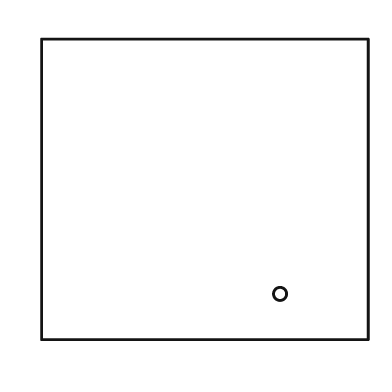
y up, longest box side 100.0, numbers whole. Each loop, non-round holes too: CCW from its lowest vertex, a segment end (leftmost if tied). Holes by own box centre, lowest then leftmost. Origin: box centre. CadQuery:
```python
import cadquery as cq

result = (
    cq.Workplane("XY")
    .moveTo(-50.0, -46.0)
    .lineTo(50.0, -46.0)
    .lineTo(50.0, 46.0)
    .lineTo(-50.0, 46.0)
    .close()
    .moveTo(23.0, -32.0)
    .circle(2.0)
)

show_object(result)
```